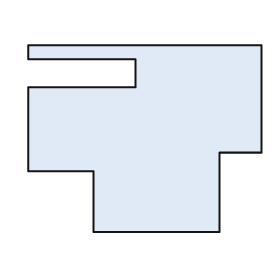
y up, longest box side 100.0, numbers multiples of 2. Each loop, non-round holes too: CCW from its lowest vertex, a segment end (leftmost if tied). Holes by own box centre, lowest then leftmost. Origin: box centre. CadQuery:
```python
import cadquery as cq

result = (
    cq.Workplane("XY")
    .moveTo(-22.0, -40.0)
    .lineTo(32.0, -40.0)
    .lineTo(32.0, -6.0)
    .lineTo(50.0, -6.0)
    .lineTo(50.0, 40.0)
    .lineTo(-50.0, 40.0)
    .lineTo(-50.0, 34.0)
    .lineTo(-4.0, 34.0)
    .lineTo(-4.0, 22.0)
    .lineTo(-50.0, 22.0)
    .lineTo(-50.0, -14.0)
    .lineTo(-22.0, -14.0)
    .close()
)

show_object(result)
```